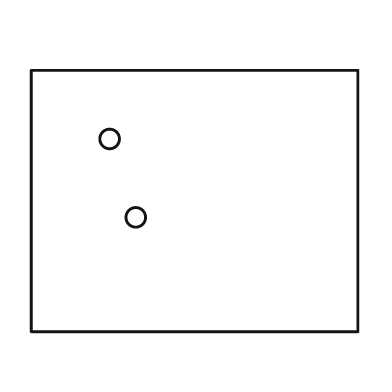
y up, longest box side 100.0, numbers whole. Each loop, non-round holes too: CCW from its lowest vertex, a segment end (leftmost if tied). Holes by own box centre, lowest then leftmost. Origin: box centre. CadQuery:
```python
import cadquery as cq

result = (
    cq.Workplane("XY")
    .moveTo(-50.0, -40.0)
    .lineTo(50.0, -40.0)
    .lineTo(50.0, 40.0)
    .lineTo(-50.0, 40.0)
    .close()
    .moveTo(-18.0, -5.0)
    .circle(3.0)
    .moveTo(-26.0, 19.0)
    .circle(3.0)
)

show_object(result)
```